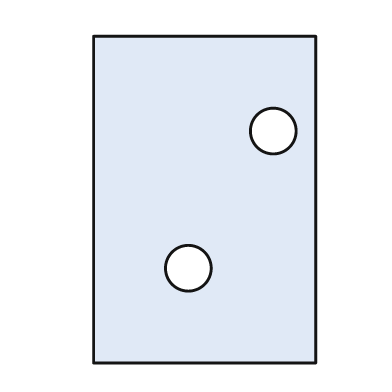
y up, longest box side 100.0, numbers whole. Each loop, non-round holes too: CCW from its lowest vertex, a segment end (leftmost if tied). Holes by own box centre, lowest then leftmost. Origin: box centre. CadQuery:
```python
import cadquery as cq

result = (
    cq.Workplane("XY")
    .moveTo(-34.0, -50.0)
    .lineTo(34.0, -50.0)
    .lineTo(34.0, 50.0)
    .lineTo(-34.0, 50.0)
    .close()
    .moveTo(-5.0, -21.0)
    .circle(7.0)
    .moveTo(21.0, 21.0)
    .circle(7.0)
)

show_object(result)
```